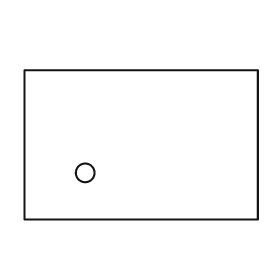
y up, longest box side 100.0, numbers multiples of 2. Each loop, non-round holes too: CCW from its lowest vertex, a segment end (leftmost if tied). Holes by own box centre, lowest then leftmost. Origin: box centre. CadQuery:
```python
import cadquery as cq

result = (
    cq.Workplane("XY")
    .moveTo(-50.0, -32.0)
    .lineTo(50.0, -32.0)
    .lineTo(50.0, 32.0)
    .lineTo(-50.0, 32.0)
    .close()
    .moveTo(-24.0, -12.0)
    .circle(4.0)
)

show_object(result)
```